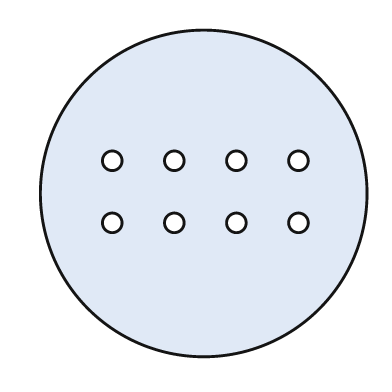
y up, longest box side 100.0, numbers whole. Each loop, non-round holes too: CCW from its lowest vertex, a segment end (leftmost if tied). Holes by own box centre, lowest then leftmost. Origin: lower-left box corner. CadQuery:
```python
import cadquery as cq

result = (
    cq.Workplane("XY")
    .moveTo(50.0, 50.0)
    .circle(50.0)
    .moveTo(22.0, 41.0)
    .circle(3.0)
    .moveTo(41.0, 41.0)
    .circle(3.0)
    .moveTo(60.0, 41.0)
    .circle(3.0)
    .moveTo(79.0, 41.0)
    .circle(3.0)
    .moveTo(22.0, 60.0)
    .circle(3.0)
    .moveTo(41.0, 60.0)
    .circle(3.0)
    .moveTo(60.0, 60.0)
    .circle(3.0)
    .moveTo(79.0, 60.0)
    .circle(3.0)
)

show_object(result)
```